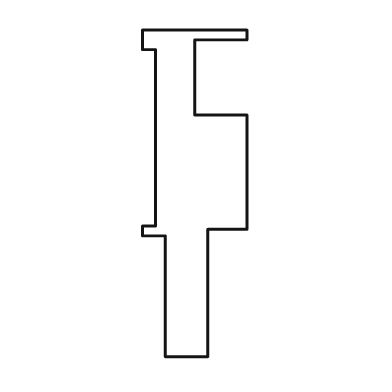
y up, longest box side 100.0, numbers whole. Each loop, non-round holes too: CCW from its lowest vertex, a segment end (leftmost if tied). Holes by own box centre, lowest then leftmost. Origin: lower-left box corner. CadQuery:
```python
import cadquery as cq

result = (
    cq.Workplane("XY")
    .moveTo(7.0, 0.0)
    .lineTo(20.0, 0.0)
    .lineTo(20.0, 39.0)
    .lineTo(32.0, 39.0)
    .lineTo(32.0, 74.0)
    .lineTo(16.0, 74.0)
    .lineTo(16.0, 97.0)
    .lineTo(32.0, 97.0)
    .lineTo(32.0, 100.0)
    .lineTo(0.0, 100.0)
    .lineTo(0.0, 94.0)
    .lineTo(4.0, 94.0)
    .lineTo(4.0, 40.0)
    .lineTo(0.0, 40.0)
    .lineTo(0.0, 37.0)
    .lineTo(7.0, 37.0)
    .close()
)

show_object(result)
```